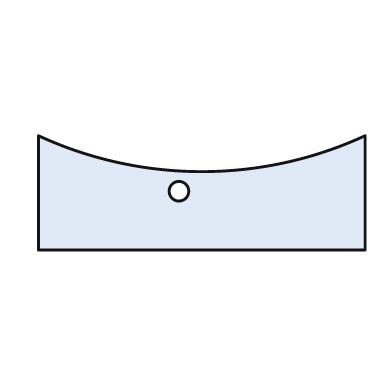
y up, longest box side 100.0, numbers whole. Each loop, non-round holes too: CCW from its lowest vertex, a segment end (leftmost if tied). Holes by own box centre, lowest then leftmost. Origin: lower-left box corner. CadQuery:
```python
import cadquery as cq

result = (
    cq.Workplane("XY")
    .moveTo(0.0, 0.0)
    .lineTo(100.0, 0.0)
    .lineTo(100.0, 35.0)
    .threePointArc((50.0, 24.0), (0.0, 35.0))
    .close()
    .moveTo(43.0, 18.0)
    .circle(3.0)
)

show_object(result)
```